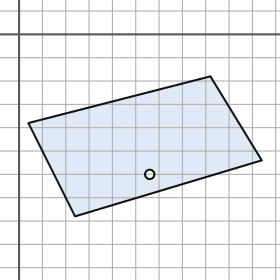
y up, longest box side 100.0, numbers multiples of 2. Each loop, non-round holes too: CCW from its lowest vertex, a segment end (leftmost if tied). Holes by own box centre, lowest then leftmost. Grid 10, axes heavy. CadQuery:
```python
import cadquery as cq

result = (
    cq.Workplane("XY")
    .moveTo(24.0, -78.0)
    .lineTo(104.0, -54.0)
    .lineTo(82.0, -18.0)
    .lineTo(4.0, -38.0)
    .close()
    .moveTo(56.0, -60.0)
    .circle(2.0)
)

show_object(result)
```